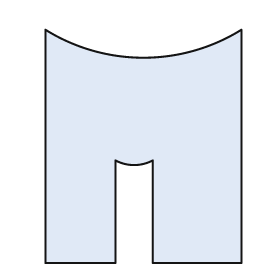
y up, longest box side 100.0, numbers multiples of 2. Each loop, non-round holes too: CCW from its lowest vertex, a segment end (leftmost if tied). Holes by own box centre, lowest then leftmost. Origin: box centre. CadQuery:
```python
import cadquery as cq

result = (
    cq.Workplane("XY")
    .moveTo(-42.0, -50.0)
    .lineTo(-12.0, -50.0)
    .lineTo(-12.0, -6.0)
    .threePointArc((-4.0, -8.0), (4.0, -6.0))
    .lineTo(4.0, -50.0)
    .lineTo(42.0, -50.0)
    .lineTo(42.0, 50.0)
    .threePointArc((0.0, 38.0), (-42.0, 50.0))
    .close()
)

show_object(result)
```